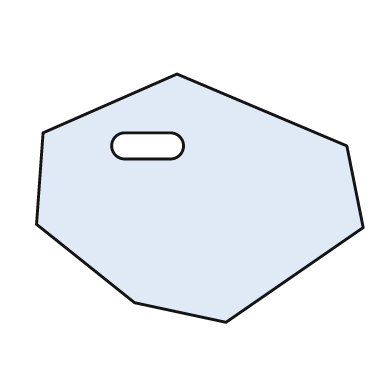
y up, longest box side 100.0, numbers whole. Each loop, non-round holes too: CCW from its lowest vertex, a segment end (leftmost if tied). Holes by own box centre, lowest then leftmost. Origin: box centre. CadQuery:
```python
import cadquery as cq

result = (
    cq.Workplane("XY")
    .moveTo(8.0, -38.0)
    .lineTo(50.0, -9.0)
    .lineTo(45.0, 16.0)
    .lineTo(-7.0, 38.0)
    .lineTo(-48.0, 20.0)
    .lineTo(-50.0, -8.0)
    .lineTo(-20.0, -32.0)
    .close()
    .moveTo(-23.0, 12.0)
    .lineTo(-9.0, 12.0)
    .threePointArc((-5.0, 16.0), (-9.0, 20.0))
    .lineTo(-23.0, 20.0)
    .threePointArc((-27.0, 16.0), (-23.0, 12.0))
    .close()
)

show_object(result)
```